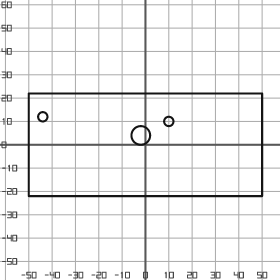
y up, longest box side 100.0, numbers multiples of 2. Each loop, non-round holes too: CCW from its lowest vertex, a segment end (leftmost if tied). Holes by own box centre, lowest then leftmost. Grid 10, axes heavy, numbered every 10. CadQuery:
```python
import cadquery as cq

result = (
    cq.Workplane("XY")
    .moveTo(-50.0, -22.0)
    .lineTo(50.0, -22.0)
    .lineTo(50.0, 22.0)
    .lineTo(-50.0, 22.0)
    .close()
    .moveTo(-2.0, 4.0)
    .circle(4.0)
    .moveTo(10.0, 10.0)
    .circle(2.0)
    .moveTo(-44.0, 12.0)
    .circle(2.0)
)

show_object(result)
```